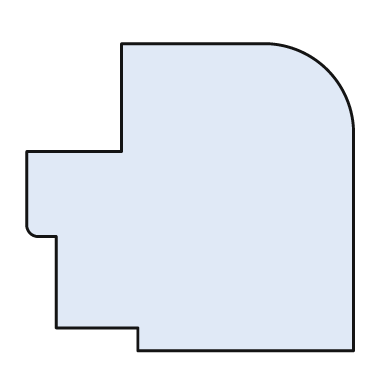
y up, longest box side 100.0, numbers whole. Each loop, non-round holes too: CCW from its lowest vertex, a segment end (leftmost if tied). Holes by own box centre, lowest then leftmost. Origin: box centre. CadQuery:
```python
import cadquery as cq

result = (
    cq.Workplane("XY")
    .moveTo(-16.0, -47.0)
    .lineTo(50.0, -47.0)
    .lineTo(50.0, 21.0)
    .threePointArc((42.0, 39.0), (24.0, 47.0))
    .lineTo(-21.0, 47.0)
    .lineTo(-21.0, 14.0)
    .lineTo(-50.0, 14.0)
    .lineTo(-50.0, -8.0)
    .threePointArc((-49.0, -11.0), (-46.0, -12.0))
    .lineTo(-41.0, -12.0)
    .lineTo(-41.0, -40.0)
    .lineTo(-16.0, -40.0)
    .close()
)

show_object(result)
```